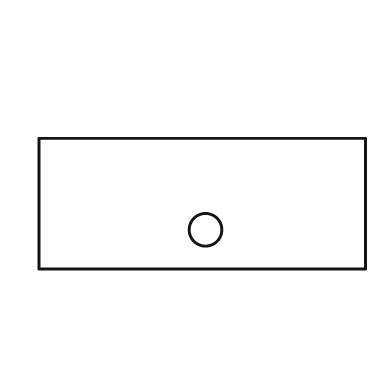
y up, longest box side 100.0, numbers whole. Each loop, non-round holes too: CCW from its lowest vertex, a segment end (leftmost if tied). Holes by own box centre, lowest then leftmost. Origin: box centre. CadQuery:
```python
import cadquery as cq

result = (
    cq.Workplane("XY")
    .moveTo(-50.0, -20.0)
    .lineTo(50.0, -20.0)
    .lineTo(50.0, 20.0)
    .lineTo(-50.0, 20.0)
    .close()
    .moveTo(1.0, -8.0)
    .circle(5.0)
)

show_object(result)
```